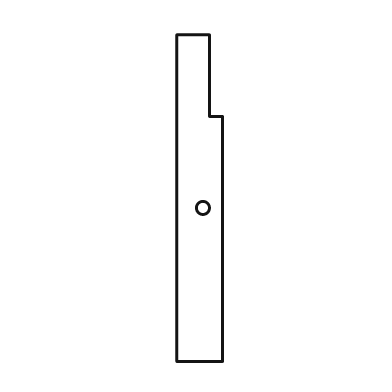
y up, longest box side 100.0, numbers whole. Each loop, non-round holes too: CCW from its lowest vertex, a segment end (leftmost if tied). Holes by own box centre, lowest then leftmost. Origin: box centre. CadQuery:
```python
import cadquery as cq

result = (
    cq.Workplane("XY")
    .moveTo(-7.0, -50.0)
    .lineTo(7.0, -50.0)
    .lineTo(7.0, 25.0)
    .lineTo(3.0, 25.0)
    .lineTo(3.0, 50.0)
    .lineTo(-7.0, 50.0)
    .close()
    .moveTo(1.0, -3.0)
    .circle(2.0)
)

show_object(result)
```